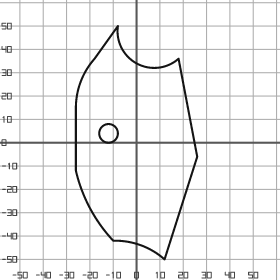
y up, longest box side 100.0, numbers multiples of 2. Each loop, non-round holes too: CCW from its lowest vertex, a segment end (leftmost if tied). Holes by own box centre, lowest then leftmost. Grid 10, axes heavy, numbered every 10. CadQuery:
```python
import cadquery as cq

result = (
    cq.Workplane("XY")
    .moveTo(12.0, -50.0)
    .lineTo(26.0, -6.0)
    .lineTo(18.0, 36.0)
    .threePointArc((0.0, 34.0), (-8.0, 50.0))
    .lineTo(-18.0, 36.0)
    .threePointArc((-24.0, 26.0), (-26.0, 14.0))
    .lineTo(-26.0, -12.0)
    .threePointArc((-20.0, -28.0), (-10.0, -42.0))
    .threePointArc((2.0, -44.0), (12.0, -50.0))
    .close()
    .moveTo(-12.0, 4.0)
    .circle(4.0)
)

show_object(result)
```